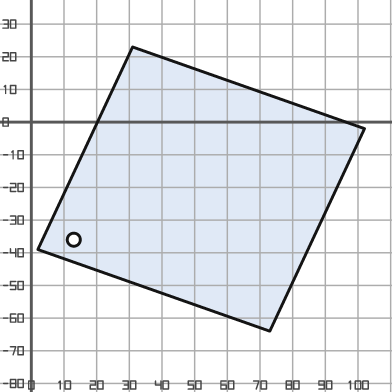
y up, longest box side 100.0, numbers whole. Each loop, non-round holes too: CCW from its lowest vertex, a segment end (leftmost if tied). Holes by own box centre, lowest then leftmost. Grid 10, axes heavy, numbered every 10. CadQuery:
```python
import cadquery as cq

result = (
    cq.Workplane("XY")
    .moveTo(73.0, -64.0)
    .lineTo(102.0, -2.0)
    .lineTo(31.0, 23.0)
    .lineTo(2.0, -39.0)
    .close()
    .moveTo(13.0, -36.0)
    .circle(2.0)
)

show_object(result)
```